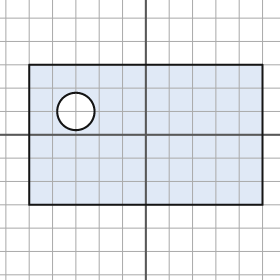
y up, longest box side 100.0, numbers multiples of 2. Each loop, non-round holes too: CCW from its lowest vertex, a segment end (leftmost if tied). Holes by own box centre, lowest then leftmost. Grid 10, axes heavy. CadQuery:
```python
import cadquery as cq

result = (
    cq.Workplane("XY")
    .moveTo(-50.0, -30.0)
    .lineTo(50.0, -30.0)
    .lineTo(50.0, 30.0)
    .lineTo(-50.0, 30.0)
    .close()
    .moveTo(-30.0, 10.0)
    .circle(8.0)
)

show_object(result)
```